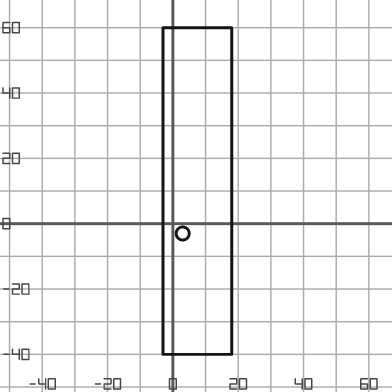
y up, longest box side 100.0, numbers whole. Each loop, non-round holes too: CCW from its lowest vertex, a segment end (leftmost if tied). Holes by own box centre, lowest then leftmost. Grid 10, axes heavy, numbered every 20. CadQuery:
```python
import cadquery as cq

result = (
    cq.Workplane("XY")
    .moveTo(-3.0, -40.0)
    .lineTo(18.0, -40.0)
    .lineTo(18.0, 60.0)
    .lineTo(-3.0, 60.0)
    .close()
    .moveTo(3.0, -3.0)
    .circle(2.0)
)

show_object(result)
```